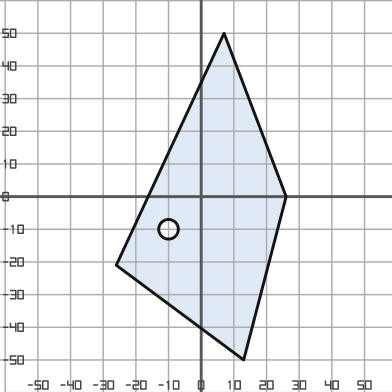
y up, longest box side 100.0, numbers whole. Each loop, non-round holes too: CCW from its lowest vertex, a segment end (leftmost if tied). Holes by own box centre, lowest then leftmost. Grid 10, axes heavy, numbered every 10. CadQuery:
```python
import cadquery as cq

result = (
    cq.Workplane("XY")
    .moveTo(13.0, -50.0)
    .lineTo(26.0, 0.0)
    .lineTo(7.0, 50.0)
    .lineTo(-26.0, -21.0)
    .close()
    .moveTo(-10.0, -10.0)
    .circle(3.0)
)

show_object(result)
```